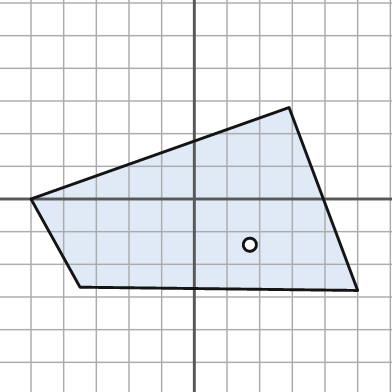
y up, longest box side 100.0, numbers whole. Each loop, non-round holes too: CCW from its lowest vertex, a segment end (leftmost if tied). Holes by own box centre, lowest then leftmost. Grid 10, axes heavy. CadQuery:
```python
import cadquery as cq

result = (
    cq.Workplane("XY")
    .moveTo(50.0, -28.0)
    .lineTo(29.0, 28.0)
    .lineTo(-50.0, 0.0)
    .lineTo(-35.0, -27.0)
    .close()
    .moveTo(17.0, -14.0)
    .circle(2.0)
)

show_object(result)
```